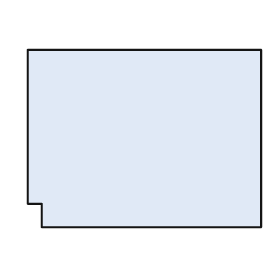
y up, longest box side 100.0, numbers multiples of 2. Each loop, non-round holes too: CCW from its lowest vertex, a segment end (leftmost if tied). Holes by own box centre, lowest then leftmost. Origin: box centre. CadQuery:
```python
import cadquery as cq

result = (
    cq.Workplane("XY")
    .moveTo(-44.0, -38.0)
    .lineTo(50.0, -38.0)
    .lineTo(50.0, 38.0)
    .lineTo(-50.0, 38.0)
    .lineTo(-50.0, -28.0)
    .lineTo(-44.0, -28.0)
    .close()
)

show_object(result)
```